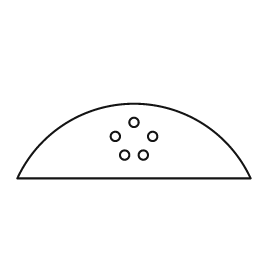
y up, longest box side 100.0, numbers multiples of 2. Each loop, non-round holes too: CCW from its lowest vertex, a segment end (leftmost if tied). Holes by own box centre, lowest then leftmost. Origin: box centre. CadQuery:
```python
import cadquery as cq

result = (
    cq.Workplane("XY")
    .moveTo(-50.0, -16.0)
    .lineTo(50.0, -16.0)
    .threePointArc((0.0, 16.0), (-50.0, -16.0))
    .close()
    .moveTo(-4.0, -6.0)
    .circle(2.0)
    .moveTo(4.0, -6.0)
    .circle(2.0)
    .moveTo(-8.0, 2.0)
    .circle(2.0)
    .moveTo(8.0, 2.0)
    .circle(2.0)
    .moveTo(0.0, 8.0)
    .circle(2.0)
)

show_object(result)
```